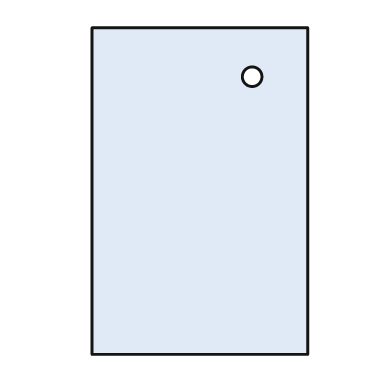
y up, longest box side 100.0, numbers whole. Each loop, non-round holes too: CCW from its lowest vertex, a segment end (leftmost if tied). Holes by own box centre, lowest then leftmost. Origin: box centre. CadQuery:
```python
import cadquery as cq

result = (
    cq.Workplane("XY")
    .moveTo(-33.0, -50.0)
    .lineTo(33.0, -50.0)
    .lineTo(33.0, 50.0)
    .lineTo(-33.0, 50.0)
    .close()
    .moveTo(16.0, 35.0)
    .circle(3.0)
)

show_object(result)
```